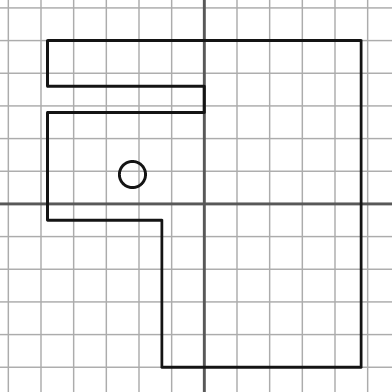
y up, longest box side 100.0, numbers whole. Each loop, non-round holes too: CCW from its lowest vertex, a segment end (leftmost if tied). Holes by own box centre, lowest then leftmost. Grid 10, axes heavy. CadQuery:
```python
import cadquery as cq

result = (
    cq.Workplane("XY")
    .moveTo(-13.0, -50.0)
    .lineTo(48.0, -50.0)
    .lineTo(48.0, 50.0)
    .lineTo(-48.0, 50.0)
    .lineTo(-48.0, 36.0)
    .lineTo(0.0, 36.0)
    .lineTo(0.0, 28.0)
    .lineTo(-48.0, 28.0)
    .lineTo(-48.0, -5.0)
    .lineTo(-13.0, -5.0)
    .close()
    .moveTo(-22.0, 9.0)
    .circle(4.0)
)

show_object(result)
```